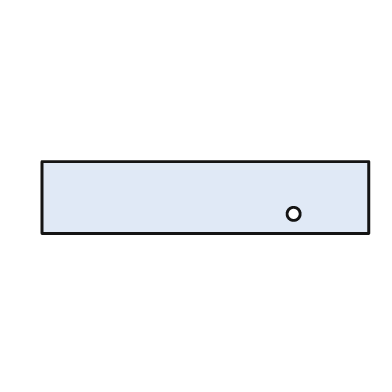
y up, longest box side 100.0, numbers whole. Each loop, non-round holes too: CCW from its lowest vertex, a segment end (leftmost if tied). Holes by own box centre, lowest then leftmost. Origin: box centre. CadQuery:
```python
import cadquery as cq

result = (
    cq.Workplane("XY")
    .moveTo(-50.0, -11.0)
    .lineTo(50.0, -11.0)
    .lineTo(50.0, 11.0)
    .lineTo(-50.0, 11.0)
    .close()
    .moveTo(27.0, -5.0)
    .circle(2.0)
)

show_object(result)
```